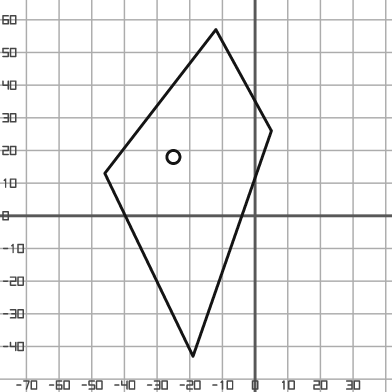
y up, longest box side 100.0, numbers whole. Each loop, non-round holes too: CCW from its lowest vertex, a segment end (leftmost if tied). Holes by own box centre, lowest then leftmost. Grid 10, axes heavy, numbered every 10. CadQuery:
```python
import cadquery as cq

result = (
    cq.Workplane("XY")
    .moveTo(-19.0, -43.0)
    .lineTo(5.0, 26.0)
    .lineTo(-12.0, 57.0)
    .lineTo(-46.0, 13.0)
    .close()
    .moveTo(-25.0, 18.0)
    .circle(2.0)
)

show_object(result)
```